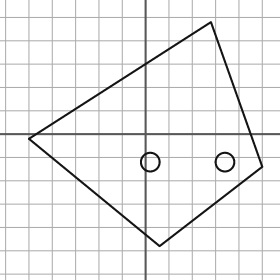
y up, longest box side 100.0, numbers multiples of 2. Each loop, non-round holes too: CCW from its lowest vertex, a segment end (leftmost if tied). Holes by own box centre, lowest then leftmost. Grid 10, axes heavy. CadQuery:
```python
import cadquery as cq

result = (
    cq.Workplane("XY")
    .moveTo(6.0, -48.0)
    .lineTo(50.0, -14.0)
    .lineTo(28.0, 48.0)
    .lineTo(-50.0, -2.0)
    .close()
    .moveTo(2.0, -12.0)
    .circle(4.0)
    .moveTo(34.0, -12.0)
    .circle(4.0)
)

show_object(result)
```